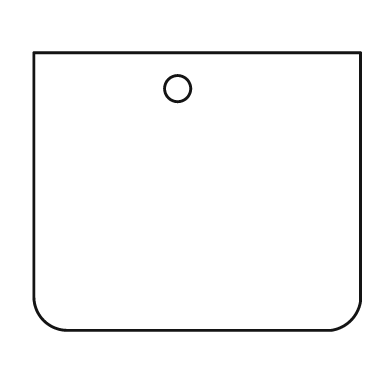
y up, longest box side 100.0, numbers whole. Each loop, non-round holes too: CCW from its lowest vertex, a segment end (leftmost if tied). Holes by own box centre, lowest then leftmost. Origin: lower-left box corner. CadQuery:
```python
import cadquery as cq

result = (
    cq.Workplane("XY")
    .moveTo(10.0, 0.0)
    .lineTo(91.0, 0.0)
    .threePointArc((97.0, 3.0), (100.0, 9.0))
    .lineTo(100.0, 85.0)
    .lineTo(0.0, 85.0)
    .lineTo(0.0, 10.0)
    .threePointArc((3.0, 3.0), (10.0, 0.0))
    .close()
    .moveTo(44.0, 74.0)
    .circle(4.0)
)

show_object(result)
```